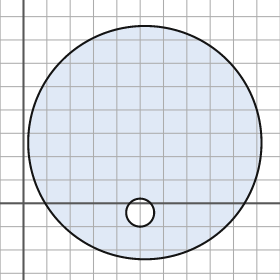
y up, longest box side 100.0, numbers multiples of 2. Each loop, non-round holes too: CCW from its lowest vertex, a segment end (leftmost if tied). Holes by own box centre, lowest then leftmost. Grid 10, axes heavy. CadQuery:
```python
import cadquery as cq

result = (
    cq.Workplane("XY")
    .moveTo(52.0, 26.0)
    .circle(50.0)
    .moveTo(50.0, -4.0)
    .circle(6.0)
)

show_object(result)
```